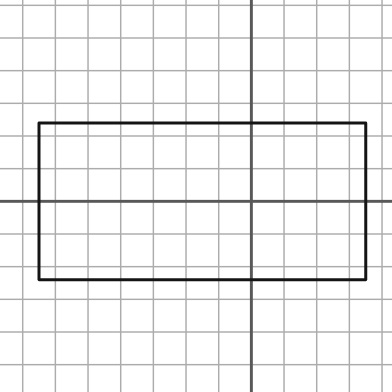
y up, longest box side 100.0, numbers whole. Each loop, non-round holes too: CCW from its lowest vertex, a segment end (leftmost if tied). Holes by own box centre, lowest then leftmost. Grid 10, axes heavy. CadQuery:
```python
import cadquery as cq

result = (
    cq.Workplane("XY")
    .moveTo(-65.0, -24.0)
    .lineTo(35.0, -24.0)
    .lineTo(35.0, 24.0)
    .lineTo(-65.0, 24.0)
    .close()
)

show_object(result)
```